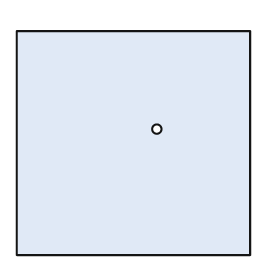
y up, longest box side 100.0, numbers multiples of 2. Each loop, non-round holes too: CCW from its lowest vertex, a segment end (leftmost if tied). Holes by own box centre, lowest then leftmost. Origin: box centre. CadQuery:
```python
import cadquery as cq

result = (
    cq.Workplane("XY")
    .moveTo(-50.0, -48.0)
    .lineTo(50.0, -48.0)
    .lineTo(50.0, 48.0)
    .lineTo(-50.0, 48.0)
    .close()
    .moveTo(10.0, 6.0)
    .circle(2.0)
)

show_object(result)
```